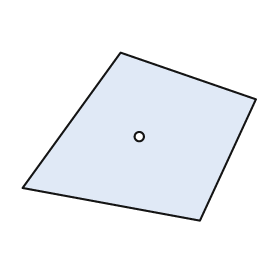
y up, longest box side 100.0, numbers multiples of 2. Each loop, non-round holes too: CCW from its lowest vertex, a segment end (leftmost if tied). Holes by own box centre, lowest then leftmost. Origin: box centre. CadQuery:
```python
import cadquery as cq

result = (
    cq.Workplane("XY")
    .moveTo(26.0, -36.0)
    .lineTo(50.0, 16.0)
    .lineTo(-8.0, 36.0)
    .lineTo(-50.0, -22.0)
    .close()
    .moveTo(0.0, 0.0)
    .circle(2.0)
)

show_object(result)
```